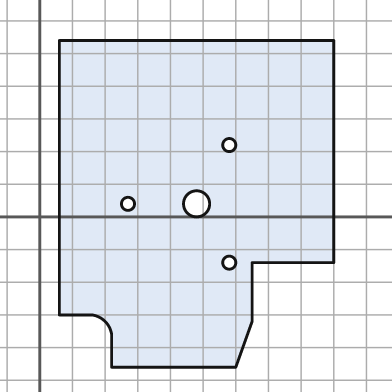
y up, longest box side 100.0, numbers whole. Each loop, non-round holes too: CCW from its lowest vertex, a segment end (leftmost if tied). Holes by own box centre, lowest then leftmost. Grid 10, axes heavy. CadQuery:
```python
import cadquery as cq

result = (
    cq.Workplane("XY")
    .moveTo(22.0, -46.0)
    .lineTo(60.0, -46.0)
    .lineTo(65.0, -32.0)
    .lineTo(65.0, -14.0)
    .lineTo(90.0, -14.0)
    .lineTo(90.0, 54.0)
    .lineTo(6.0, 54.0)
    .lineTo(6.0, -30.0)
    .lineTo(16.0, -30.0)
    .threePointArc((20.0, -32.0), (22.0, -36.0))
    .close()
    .moveTo(58.0, -14.0)
    .circle(2.0)
    .moveTo(27.0, 4.0)
    .circle(2.0)
    .moveTo(48.0, 4.0)
    .circle(4.0)
    .moveTo(58.0, 22.0)
    .circle(2.0)
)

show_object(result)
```